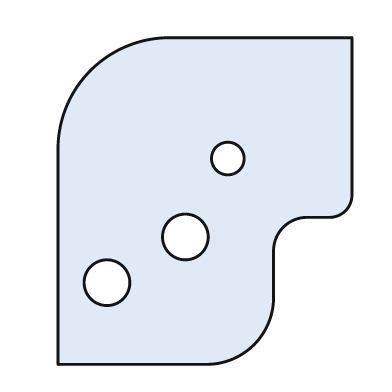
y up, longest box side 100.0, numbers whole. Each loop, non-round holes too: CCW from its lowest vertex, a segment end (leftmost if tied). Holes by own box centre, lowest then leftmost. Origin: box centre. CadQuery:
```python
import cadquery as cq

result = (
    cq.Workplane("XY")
    .moveTo(-45.0, -50.0)
    .lineTo(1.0, -50.0)
    .threePointArc((15.0, -44.0), (21.0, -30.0))
    .lineTo(21.0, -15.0)
    .threePointArc((24.0, -8.0), (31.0, -5.0))
    .lineTo(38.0, -5.0)
    .threePointArc((43.0, -3.0), (45.0, 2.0))
    .lineTo(45.0, 50.0)
    .lineTo(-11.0, 50.0)
    .threePointArc((-35.0, 40.0), (-45.0, 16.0))
    .close()
    .moveTo(-30.0, -25.0)
    .circle(7.0)
    .moveTo(-6.0, -11.0)
    .circle(7.0)
    .moveTo(7.0, 13.0)
    .circle(5.0)
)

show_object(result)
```